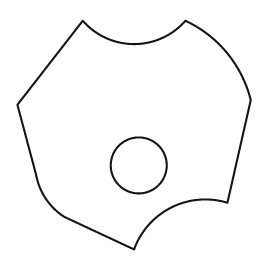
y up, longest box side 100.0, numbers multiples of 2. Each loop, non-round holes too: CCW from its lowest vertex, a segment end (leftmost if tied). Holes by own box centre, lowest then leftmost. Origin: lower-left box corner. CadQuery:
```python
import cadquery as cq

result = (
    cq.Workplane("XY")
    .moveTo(50.0, 0.0)
    .threePointArc((66.0, 18.0), (90.0, 20.0))
    .lineTo(100.0, 64.0)
    .threePointArc((90.0, 84.0), (72.0, 98.0))
    .threePointArc((50.0, 88.0), (28.0, 98.0))
    .lineTo(0.0, 62.0)
    .lineTo(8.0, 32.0)
    .threePointArc((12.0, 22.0), (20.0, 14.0))
    .close()
    .moveTo(52.0, 36.0)
    .circle(12.0)
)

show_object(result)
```